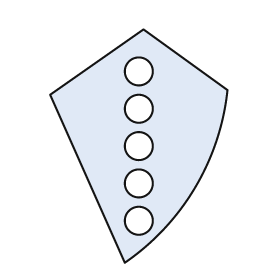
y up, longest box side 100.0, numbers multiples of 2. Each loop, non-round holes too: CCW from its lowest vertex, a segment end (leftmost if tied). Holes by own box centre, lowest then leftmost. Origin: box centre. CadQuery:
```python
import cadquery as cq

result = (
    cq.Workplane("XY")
    .moveTo(-6.0, -50.0)
    .threePointArc((24.0, -18.0), (38.0, 24.0))
    .lineTo(2.0, 50.0)
    .lineTo(-38.0, 22.0)
    .close()
    .moveTo(0.0, -32.0)
    .circle(6.0)
    .moveTo(0.0, -16.0)
    .circle(6.0)
    .moveTo(0.0, 0.0)
    .circle(6.0)
    .moveTo(0.0, 16.0)
    .circle(6.0)
    .moveTo(0.0, 32.0)
    .circle(6.0)
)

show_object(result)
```